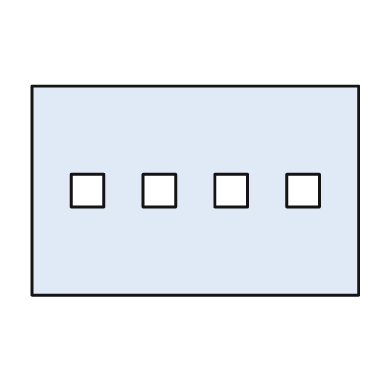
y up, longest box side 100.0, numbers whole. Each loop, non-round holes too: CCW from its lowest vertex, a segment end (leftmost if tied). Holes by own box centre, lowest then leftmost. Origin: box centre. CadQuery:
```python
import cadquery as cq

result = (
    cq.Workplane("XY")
    .moveTo(-50.0, -32.0)
    .lineTo(50.0, -32.0)
    .lineTo(50.0, 32.0)
    .lineTo(-50.0, 32.0)
    .close()
    .moveTo(-38.0, -5.0)
    .lineTo(-28.0, -5.0)
    .lineTo(-28.0, 5.0)
    .lineTo(-38.0, 5.0)
    .close()
    .moveTo(-16.0, -5.0)
    .lineTo(-6.0, -5.0)
    .lineTo(-6.0, 5.0)
    .lineTo(-16.0, 5.0)
    .close()
    .moveTo(6.0, -5.0)
    .lineTo(16.0, -5.0)
    .lineTo(16.0, 5.0)
    .lineTo(6.0, 5.0)
    .close()
    .moveTo(28.0, -5.0)
    .lineTo(38.0, -5.0)
    .lineTo(38.0, 5.0)
    .lineTo(28.0, 5.0)
    .close()
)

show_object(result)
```